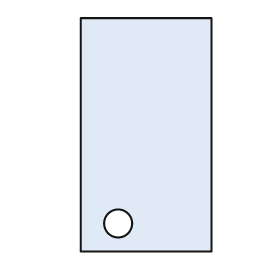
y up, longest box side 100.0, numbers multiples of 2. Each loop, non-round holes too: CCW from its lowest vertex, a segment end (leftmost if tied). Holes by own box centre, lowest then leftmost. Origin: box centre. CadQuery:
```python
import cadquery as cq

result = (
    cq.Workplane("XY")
    .moveTo(-28.0, -50.0)
    .lineTo(28.0, -50.0)
    .lineTo(28.0, 50.0)
    .lineTo(-28.0, 50.0)
    .close()
    .moveTo(-12.0, -38.0)
    .circle(6.0)
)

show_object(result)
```